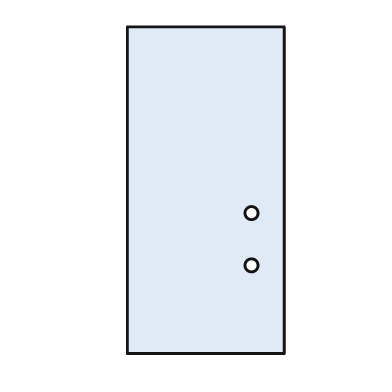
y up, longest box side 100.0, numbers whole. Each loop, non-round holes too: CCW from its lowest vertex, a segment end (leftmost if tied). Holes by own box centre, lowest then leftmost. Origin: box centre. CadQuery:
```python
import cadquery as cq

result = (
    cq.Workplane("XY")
    .moveTo(-24.0, -50.0)
    .lineTo(24.0, -50.0)
    .lineTo(24.0, 50.0)
    .lineTo(-24.0, 50.0)
    .close()
    .moveTo(14.0, -23.0)
    .circle(2.0)
    .moveTo(14.0, -7.0)
    .circle(2.0)
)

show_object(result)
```